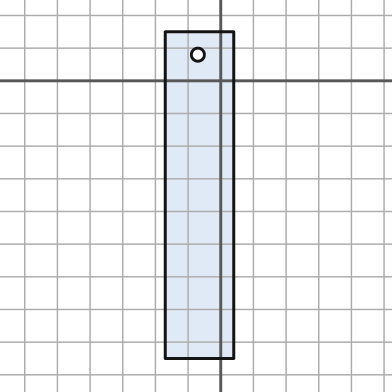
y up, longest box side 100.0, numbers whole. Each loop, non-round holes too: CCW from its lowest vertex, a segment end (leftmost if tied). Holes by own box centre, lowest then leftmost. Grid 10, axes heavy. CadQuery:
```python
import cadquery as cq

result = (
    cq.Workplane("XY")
    .moveTo(-17.0, -85.0)
    .lineTo(4.0, -85.0)
    .lineTo(4.0, 15.0)
    .lineTo(-17.0, 15.0)
    .close()
    .moveTo(-7.0, 8.0)
    .circle(2.0)
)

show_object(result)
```